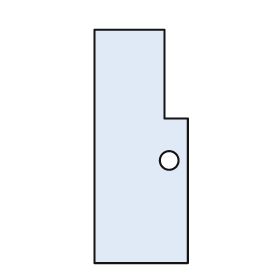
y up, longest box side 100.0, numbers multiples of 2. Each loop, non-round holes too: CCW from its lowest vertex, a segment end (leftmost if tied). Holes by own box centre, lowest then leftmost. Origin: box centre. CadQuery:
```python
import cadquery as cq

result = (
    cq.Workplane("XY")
    .moveTo(-20.0, -50.0)
    .lineTo(20.0, -50.0)
    .lineTo(20.0, 12.0)
    .lineTo(10.0, 12.0)
    .lineTo(10.0, 50.0)
    .lineTo(-20.0, 50.0)
    .close()
    .moveTo(12.0, -6.0)
    .circle(4.0)
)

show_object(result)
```